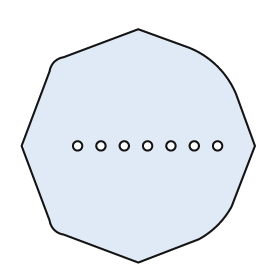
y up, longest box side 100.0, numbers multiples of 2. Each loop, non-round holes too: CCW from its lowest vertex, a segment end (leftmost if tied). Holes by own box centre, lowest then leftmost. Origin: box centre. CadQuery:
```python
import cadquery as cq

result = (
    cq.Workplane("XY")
    .moveTo(0.0, -50.0)
    .lineTo(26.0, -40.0)
    .threePointArc((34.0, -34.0), (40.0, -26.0))
    .lineTo(50.0, 0.0)
    .lineTo(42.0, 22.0)
    .threePointArc((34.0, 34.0), (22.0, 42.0))
    .lineTo(0.0, 50.0)
    .lineTo(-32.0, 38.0)
    .threePointArc((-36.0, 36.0), (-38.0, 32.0))
    .lineTo(-50.0, 0.0)
    .lineTo(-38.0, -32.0)
    .threePointArc((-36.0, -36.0), (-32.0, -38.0))
    .close()
    .moveTo(-26.0, 0.0)
    .circle(2.0)
    .moveTo(-16.0, 0.0)
    .circle(2.0)
    .moveTo(-6.0, 0.0)
    .circle(2.0)
    .moveTo(4.0, 0.0)
    .circle(2.0)
    .moveTo(14.0, 0.0)
    .circle(2.0)
    .moveTo(24.0, 0.0)
    .circle(2.0)
    .moveTo(34.0, 0.0)
    .circle(2.0)
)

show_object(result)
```